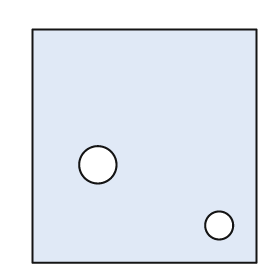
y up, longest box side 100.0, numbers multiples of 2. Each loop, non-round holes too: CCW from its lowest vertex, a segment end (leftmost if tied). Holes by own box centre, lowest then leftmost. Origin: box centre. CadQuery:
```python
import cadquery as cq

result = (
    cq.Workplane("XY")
    .moveTo(-48.0, -50.0)
    .lineTo(48.0, -50.0)
    .lineTo(48.0, 50.0)
    .lineTo(-48.0, 50.0)
    .close()
    .moveTo(32.0, -34.0)
    .circle(6.0)
    .moveTo(-20.0, -8.0)
    .circle(8.0)
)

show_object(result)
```